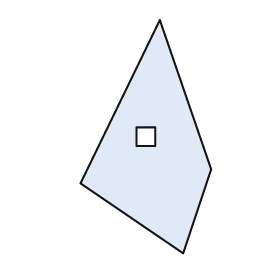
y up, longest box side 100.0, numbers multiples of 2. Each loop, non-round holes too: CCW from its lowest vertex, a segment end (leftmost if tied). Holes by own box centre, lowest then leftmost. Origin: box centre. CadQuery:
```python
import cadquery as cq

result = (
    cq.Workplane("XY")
    .moveTo(16.0, -50.0)
    .lineTo(28.0, -14.0)
    .lineTo(6.0, 50.0)
    .lineTo(-28.0, -20.0)
    .close()
    .moveTo(-4.0, -4.0)
    .lineTo(4.0, -4.0)
    .lineTo(4.0, 4.0)
    .lineTo(-4.0, 4.0)
    .close()
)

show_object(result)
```